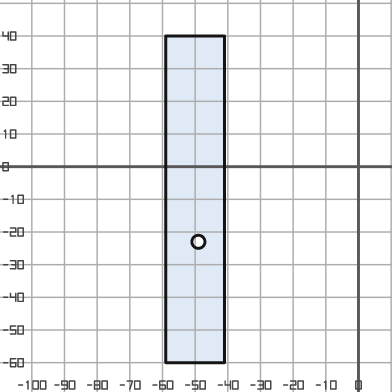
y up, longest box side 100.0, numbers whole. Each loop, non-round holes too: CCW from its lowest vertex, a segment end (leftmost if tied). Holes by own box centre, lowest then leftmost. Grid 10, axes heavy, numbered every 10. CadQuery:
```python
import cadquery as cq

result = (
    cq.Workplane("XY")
    .moveTo(-59.0, -60.0)
    .lineTo(-41.0, -60.0)
    .lineTo(-41.0, 40.0)
    .lineTo(-59.0, 40.0)
    .close()
    .moveTo(-49.0, -23.0)
    .circle(2.0)
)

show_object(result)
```